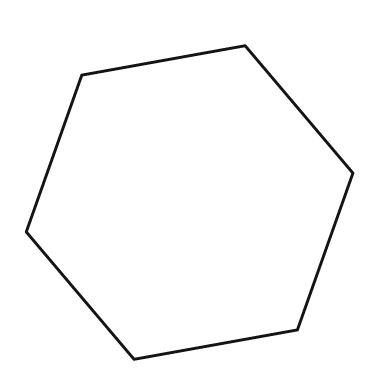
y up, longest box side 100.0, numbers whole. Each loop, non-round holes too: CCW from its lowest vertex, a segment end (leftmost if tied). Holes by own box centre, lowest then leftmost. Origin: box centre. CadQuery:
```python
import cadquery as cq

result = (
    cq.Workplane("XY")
    .moveTo(-17.0, -48.0)
    .lineTo(33.0, -39.0)
    .lineTo(50.0, 9.0)
    .lineTo(17.0, 48.0)
    .lineTo(-33.0, 39.0)
    .lineTo(-50.0, -9.0)
    .close()
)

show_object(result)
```